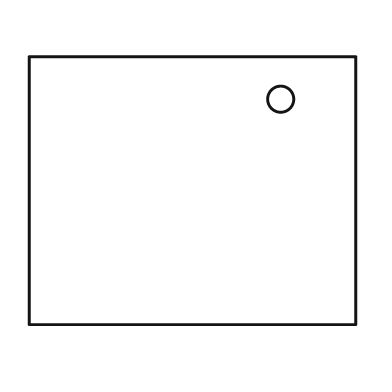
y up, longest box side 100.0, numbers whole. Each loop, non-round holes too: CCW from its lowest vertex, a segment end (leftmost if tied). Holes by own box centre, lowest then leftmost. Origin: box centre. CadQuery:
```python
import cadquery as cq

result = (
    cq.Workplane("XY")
    .moveTo(-50.0, -41.0)
    .lineTo(50.0, -41.0)
    .lineTo(50.0, 41.0)
    .lineTo(-50.0, 41.0)
    .close()
    .moveTo(27.0, 28.0)
    .circle(4.0)
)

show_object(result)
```